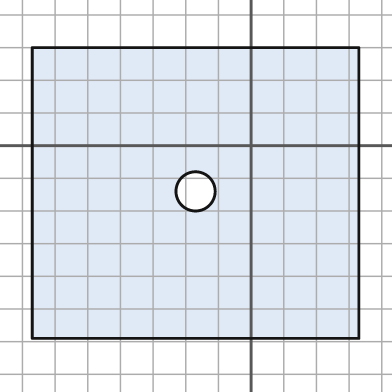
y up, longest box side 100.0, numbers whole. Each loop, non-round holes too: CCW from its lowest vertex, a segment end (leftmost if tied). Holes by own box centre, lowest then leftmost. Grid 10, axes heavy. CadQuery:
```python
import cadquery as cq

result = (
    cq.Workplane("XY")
    .moveTo(-67.0, -59.0)
    .lineTo(33.0, -59.0)
    .lineTo(33.0, 30.0)
    .lineTo(-67.0, 30.0)
    .close()
    .moveTo(-17.0, -14.0)
    .circle(6.0)
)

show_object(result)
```